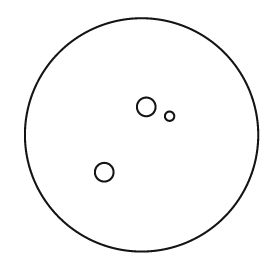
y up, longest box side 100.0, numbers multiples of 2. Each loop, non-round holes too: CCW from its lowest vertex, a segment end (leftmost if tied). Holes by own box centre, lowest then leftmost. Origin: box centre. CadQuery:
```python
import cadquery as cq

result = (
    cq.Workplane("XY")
    .moveTo(0.0, 0.0)
    .circle(50.0)
    .moveTo(-16.0, -16.0)
    .circle(4.0)
    .moveTo(12.0, 8.0)
    .circle(2.0)
    .moveTo(2.0, 12.0)
    .circle(4.0)
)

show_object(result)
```